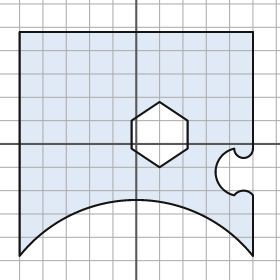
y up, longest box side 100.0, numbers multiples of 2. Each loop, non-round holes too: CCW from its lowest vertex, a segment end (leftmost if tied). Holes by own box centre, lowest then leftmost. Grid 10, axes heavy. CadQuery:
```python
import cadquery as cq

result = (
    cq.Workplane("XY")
    .moveTo(-50.0, -48.0)
    .threePointArc((0.0, -24.0), (50.0, -48.0))
    .lineTo(50.0, -22.0)
    .threePointArc((46.0, -20.0), (42.0, -22.0))
    .threePointArc((34.0, -12.0), (42.0, -2.0))
    .threePointArc((46.0, -6.0), (50.0, -2.0))
    .lineTo(50.0, 48.0)
    .lineTo(-50.0, 48.0)
    .close()
    .moveTo(10.0, -10.0)
    .lineTo(22.0, -2.0)
    .lineTo(22.0, 10.0)
    .lineTo(10.0, 18.0)
    .lineTo(-2.0, 10.0)
    .lineTo(-2.0, -2.0)
    .close()
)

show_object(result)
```